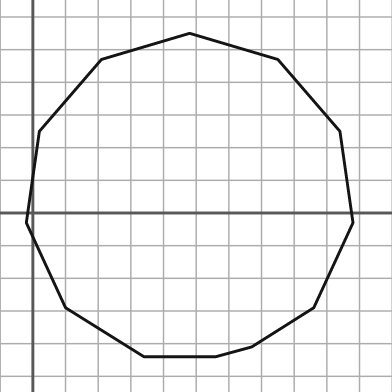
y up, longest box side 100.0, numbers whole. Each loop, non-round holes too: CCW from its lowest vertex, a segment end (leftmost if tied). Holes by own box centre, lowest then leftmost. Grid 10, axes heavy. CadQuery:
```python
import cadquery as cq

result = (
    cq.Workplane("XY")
    .moveTo(34.0, -44.0)
    .lineTo(56.0, -44.0)
    .lineTo(67.0, -41.0)
    .lineTo(86.0, -29.0)
    .lineTo(98.0, -3.0)
    .lineTo(94.0, 25.0)
    .lineTo(75.0, 47.0)
    .lineTo(48.0, 55.0)
    .lineTo(21.0, 47.0)
    .lineTo(2.0, 25.0)
    .lineTo(-2.0, -3.0)
    .lineTo(10.0, -29.0)
    .close()
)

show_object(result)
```